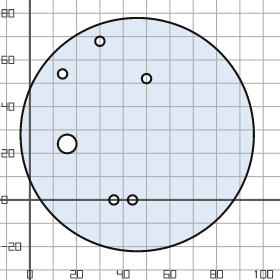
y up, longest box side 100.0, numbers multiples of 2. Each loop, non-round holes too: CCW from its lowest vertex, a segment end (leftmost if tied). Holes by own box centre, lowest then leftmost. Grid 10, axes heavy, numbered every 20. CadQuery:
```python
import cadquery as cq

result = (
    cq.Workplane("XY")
    .moveTo(46.0, 28.0)
    .circle(50.0)
    .moveTo(36.0, 0.0)
    .circle(2.0)
    .moveTo(44.0, 0.0)
    .circle(2.0)
    .moveTo(16.0, 24.0)
    .circle(4.0)
    .moveTo(50.0, 52.0)
    .circle(2.0)
    .moveTo(14.0, 54.0)
    .circle(2.0)
    .moveTo(30.0, 68.0)
    .circle(2.0)
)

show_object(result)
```